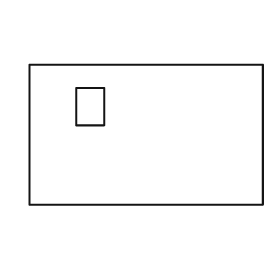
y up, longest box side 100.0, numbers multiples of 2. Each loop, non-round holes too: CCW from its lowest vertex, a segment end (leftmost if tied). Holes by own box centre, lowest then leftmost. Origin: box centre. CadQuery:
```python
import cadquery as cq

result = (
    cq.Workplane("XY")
    .moveTo(-50.0, -30.0)
    .lineTo(50.0, -30.0)
    .lineTo(50.0, 30.0)
    .lineTo(-50.0, 30.0)
    .close()
    .moveTo(-30.0, 4.0)
    .lineTo(-18.0, 4.0)
    .lineTo(-18.0, 20.0)
    .lineTo(-30.0, 20.0)
    .close()
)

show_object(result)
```